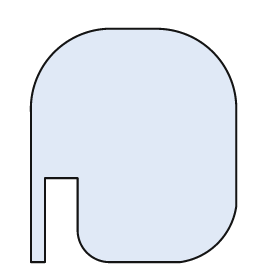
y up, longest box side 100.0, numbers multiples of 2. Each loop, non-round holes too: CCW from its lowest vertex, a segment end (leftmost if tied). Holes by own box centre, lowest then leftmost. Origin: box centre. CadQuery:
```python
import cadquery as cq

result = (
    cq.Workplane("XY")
    .moveTo(-44.0, -50.0)
    .lineTo(-38.0, -50.0)
    .lineTo(-38.0, -14.0)
    .lineTo(-24.0, -14.0)
    .lineTo(-24.0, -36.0)
    .threePointArc((-20.0, -46.0), (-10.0, -50.0))
    .lineTo(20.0, -50.0)
    .threePointArc((36.0, -42.0), (44.0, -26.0))
    .lineTo(44.0, 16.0)
    .threePointArc((34.0, 40.0), (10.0, 50.0))
    .lineTo(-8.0, 50.0)
    .threePointArc((-34.0, 40.0), (-44.0, 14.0))
    .close()
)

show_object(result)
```